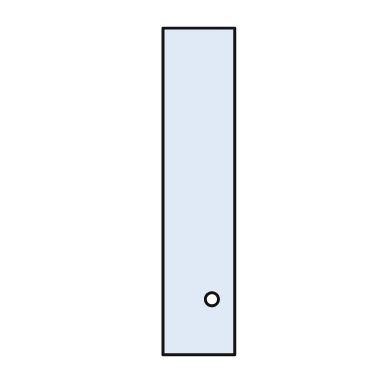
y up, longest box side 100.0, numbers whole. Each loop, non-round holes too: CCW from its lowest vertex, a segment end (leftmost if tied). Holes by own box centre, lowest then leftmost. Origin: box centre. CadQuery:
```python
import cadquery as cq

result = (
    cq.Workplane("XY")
    .moveTo(-11.0, -50.0)
    .lineTo(11.0, -50.0)
    .lineTo(11.0, 50.0)
    .lineTo(-11.0, 50.0)
    .close()
    .moveTo(4.0, -33.0)
    .circle(2.0)
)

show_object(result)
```